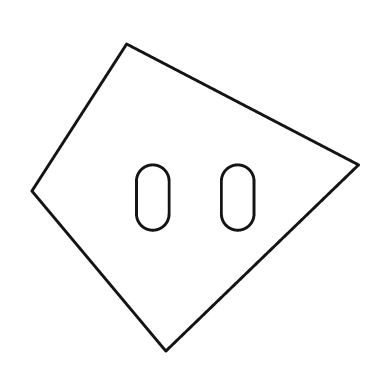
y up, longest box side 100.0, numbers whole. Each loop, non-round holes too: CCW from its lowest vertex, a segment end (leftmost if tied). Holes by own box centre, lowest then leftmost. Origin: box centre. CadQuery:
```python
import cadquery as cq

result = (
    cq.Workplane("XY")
    .moveTo(-9.0, -47.0)
    .lineTo(50.0, 10.0)
    .lineTo(-21.0, 47.0)
    .lineTo(-50.0, 2.0)
    .close()
    .moveTo(-18.0, -5.0)
    .threePointArc((-13.0, -10.0), (-8.0, -5.0))
    .lineTo(-8.0, 5.0)
    .threePointArc((-13.0, 10.0), (-18.0, 5.0))
    .close()
    .moveTo(8.0, -5.0)
    .threePointArc((13.0, -10.0), (18.0, -5.0))
    .lineTo(18.0, 5.0)
    .threePointArc((13.0, 10.0), (8.0, 5.0))
    .close()
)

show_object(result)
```